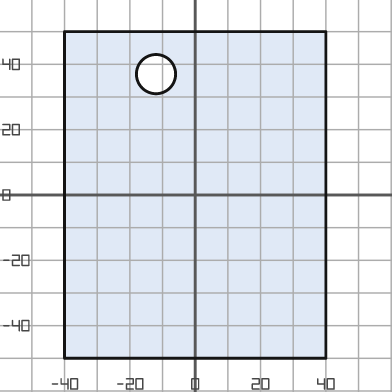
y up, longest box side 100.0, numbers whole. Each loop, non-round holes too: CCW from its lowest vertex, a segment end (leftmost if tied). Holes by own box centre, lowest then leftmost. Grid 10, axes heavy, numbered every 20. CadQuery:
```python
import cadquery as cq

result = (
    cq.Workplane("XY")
    .moveTo(-40.0, -50.0)
    .lineTo(40.0, -50.0)
    .lineTo(40.0, 50.0)
    .lineTo(-40.0, 50.0)
    .close()
    .moveTo(-12.0, 37.0)
    .circle(6.0)
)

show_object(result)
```